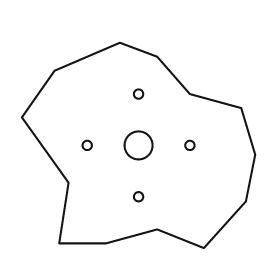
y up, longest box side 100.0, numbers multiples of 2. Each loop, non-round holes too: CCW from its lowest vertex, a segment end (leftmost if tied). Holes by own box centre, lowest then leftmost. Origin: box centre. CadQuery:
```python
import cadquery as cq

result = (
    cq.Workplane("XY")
    .moveTo(28.0, -44.0)
    .lineTo(46.0, -24.0)
    .lineTo(50.0, -4.0)
    .lineTo(44.0, 16.0)
    .lineTo(22.0, 22.0)
    .lineTo(8.0, 38.0)
    .lineTo(-8.0, 44.0)
    .lineTo(-36.0, 32.0)
    .lineTo(-50.0, 12.0)
    .lineTo(-30.0, -16.0)
    .lineTo(-34.0, -42.0)
    .lineTo(-14.0, -42.0)
    .lineTo(8.0, -36.0)
    .close()
    .moveTo(0.0, -22.0)
    .circle(2.0)
    .moveTo(-22.0, 0.0)
    .circle(2.0)
    .moveTo(0.0, 0.0)
    .circle(6.0)
    .moveTo(22.0, 0.0)
    .circle(2.0)
    .moveTo(0.0, 22.0)
    .circle(2.0)
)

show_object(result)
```